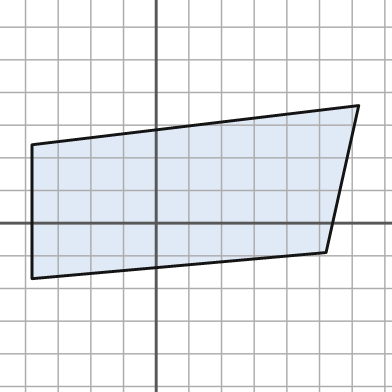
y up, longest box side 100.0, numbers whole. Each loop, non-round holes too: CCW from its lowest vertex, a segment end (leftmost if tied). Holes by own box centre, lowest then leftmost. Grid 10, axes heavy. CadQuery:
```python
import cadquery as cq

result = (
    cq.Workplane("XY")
    .moveTo(-38.0, -17.0)
    .lineTo(52.0, -9.0)
    .lineTo(62.0, 36.0)
    .lineTo(-38.0, 24.0)
    .close()
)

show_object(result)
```